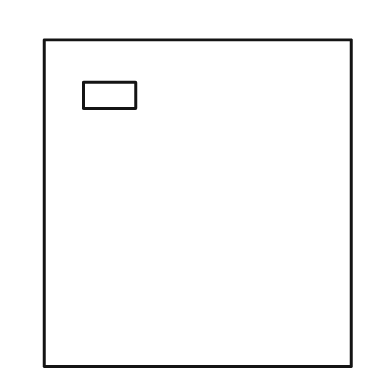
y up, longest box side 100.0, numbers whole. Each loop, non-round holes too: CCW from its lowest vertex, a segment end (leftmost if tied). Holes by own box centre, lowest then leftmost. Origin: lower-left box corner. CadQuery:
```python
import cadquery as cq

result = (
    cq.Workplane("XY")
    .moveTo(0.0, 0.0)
    .lineTo(94.0, 0.0)
    .lineTo(94.0, 100.0)
    .lineTo(0.0, 100.0)
    .close()
    .moveTo(12.0, 79.0)
    .lineTo(28.0, 79.0)
    .lineTo(28.0, 87.0)
    .lineTo(12.0, 87.0)
    .close()
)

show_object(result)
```